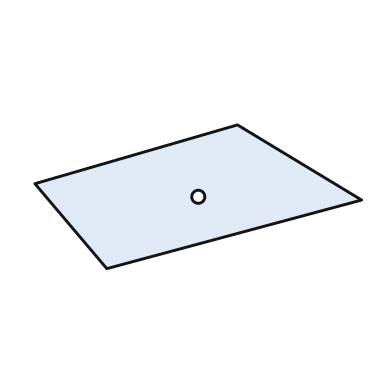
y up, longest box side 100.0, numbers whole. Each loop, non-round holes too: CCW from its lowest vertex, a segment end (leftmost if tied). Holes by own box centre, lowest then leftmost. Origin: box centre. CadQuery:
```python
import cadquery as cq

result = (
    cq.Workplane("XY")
    .moveTo(-28.0, -22.0)
    .lineTo(50.0, -1.0)
    .lineTo(12.0, 22.0)
    .lineTo(-50.0, 4.0)
    .close()
    .moveTo(0.0, 0.0)
    .circle(2.0)
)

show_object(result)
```